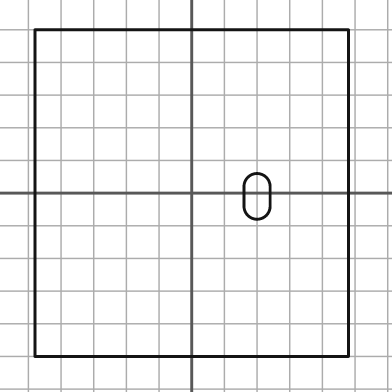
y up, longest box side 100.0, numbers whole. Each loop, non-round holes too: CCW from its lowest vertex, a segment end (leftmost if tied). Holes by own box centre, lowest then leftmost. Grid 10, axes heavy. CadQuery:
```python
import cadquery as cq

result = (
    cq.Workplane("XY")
    .moveTo(-48.0, -50.0)
    .lineTo(48.0, -50.0)
    .lineTo(48.0, 50.0)
    .lineTo(-48.0, 50.0)
    .close()
    .moveTo(16.0, -4.0)
    .threePointArc((20.0, -8.0), (24.0, -4.0))
    .lineTo(24.0, 2.0)
    .threePointArc((20.0, 6.0), (16.0, 2.0))
    .close()
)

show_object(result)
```